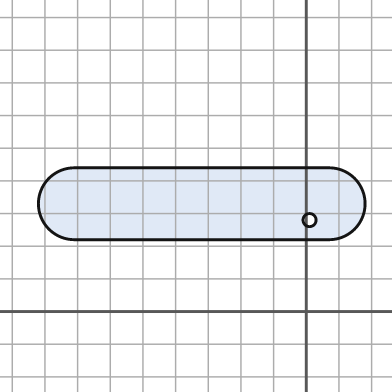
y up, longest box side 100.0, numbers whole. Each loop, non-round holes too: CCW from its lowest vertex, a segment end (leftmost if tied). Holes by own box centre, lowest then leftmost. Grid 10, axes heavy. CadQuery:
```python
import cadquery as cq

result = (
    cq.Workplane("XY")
    .moveTo(-71.0, 22.0)
    .lineTo(7.0, 22.0)
    .threePointArc((18.0, 33.0), (7.0, 44.0))
    .lineTo(-71.0, 44.0)
    .threePointArc((-82.0, 33.0), (-71.0, 22.0))
    .close()
    .moveTo(1.0, 28.0)
    .circle(2.0)
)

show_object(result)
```